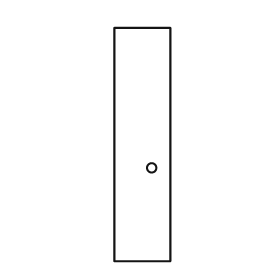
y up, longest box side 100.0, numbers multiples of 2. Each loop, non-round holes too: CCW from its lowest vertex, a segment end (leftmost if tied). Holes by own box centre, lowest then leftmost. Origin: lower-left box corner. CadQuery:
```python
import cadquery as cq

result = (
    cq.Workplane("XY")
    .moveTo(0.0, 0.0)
    .lineTo(24.0, 0.0)
    .lineTo(24.0, 100.0)
    .lineTo(0.0, 100.0)
    .close()
    .moveTo(16.0, 40.0)
    .circle(2.0)
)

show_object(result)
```